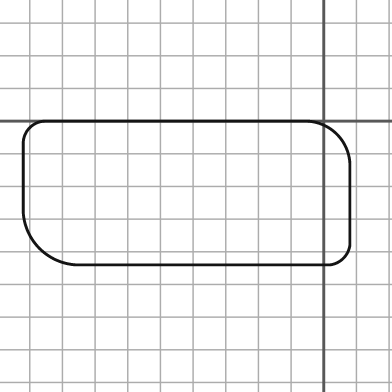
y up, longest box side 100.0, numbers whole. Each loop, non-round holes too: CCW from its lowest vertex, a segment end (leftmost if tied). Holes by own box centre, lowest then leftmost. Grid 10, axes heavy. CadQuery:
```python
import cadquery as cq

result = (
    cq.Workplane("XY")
    .moveTo(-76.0, -44.0)
    .lineTo(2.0, -44.0)
    .threePointArc((6.0, -42.0), (8.0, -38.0))
    .lineTo(8.0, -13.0)
    .threePointArc((4.0, -4.0), (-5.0, 0.0))
    .lineTo(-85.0, 0.0)
    .threePointArc((-90.0, -2.0), (-92.0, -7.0))
    .lineTo(-92.0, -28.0)
    .threePointArc((-87.0, -39.0), (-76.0, -44.0))
    .close()
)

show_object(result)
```